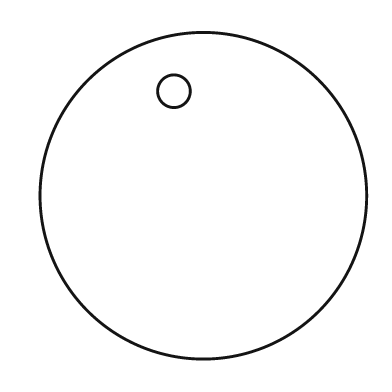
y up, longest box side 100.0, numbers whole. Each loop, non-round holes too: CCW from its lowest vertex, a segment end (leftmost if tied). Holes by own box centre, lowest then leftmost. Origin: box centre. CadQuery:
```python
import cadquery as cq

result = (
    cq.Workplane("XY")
    .moveTo(0.0, 0.0)
    .circle(50.0)
    .moveTo(-9.0, 32.0)
    .circle(5.0)
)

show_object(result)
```